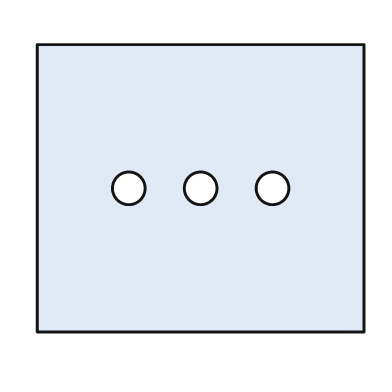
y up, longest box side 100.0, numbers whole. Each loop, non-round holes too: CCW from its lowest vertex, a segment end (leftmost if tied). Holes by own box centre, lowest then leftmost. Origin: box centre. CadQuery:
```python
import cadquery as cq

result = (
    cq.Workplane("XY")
    .moveTo(-50.0, -44.0)
    .lineTo(50.0, -44.0)
    .lineTo(50.0, 44.0)
    .lineTo(-50.0, 44.0)
    .close()
    .moveTo(-22.0, 0.0)
    .circle(5.0)
    .moveTo(0.0, 0.0)
    .circle(5.0)
    .moveTo(22.0, 0.0)
    .circle(5.0)
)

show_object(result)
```